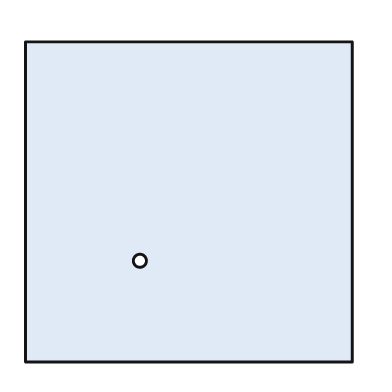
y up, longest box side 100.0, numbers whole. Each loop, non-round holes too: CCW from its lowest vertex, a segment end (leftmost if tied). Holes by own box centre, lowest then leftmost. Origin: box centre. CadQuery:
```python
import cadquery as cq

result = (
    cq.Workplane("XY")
    .moveTo(-50.0, -49.0)
    .lineTo(50.0, -49.0)
    .lineTo(50.0, 49.0)
    .lineTo(-50.0, 49.0)
    .close()
    .moveTo(-15.0, -18.0)
    .circle(2.0)
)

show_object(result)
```